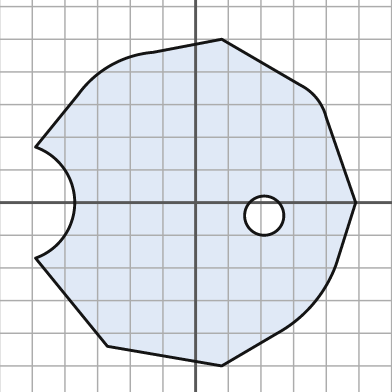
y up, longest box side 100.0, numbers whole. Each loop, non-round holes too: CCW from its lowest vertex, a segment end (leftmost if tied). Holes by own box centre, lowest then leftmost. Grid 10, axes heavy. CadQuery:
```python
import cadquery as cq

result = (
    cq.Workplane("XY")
    .moveTo(8.0, -50.0)
    .lineTo(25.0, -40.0)
    .threePointArc((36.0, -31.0), (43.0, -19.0))
    .lineTo(49.0, 0.0)
    .lineTo(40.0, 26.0)
    .threePointArc((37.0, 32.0), (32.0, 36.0))
    .lineTo(8.0, 50.0)
    .lineTo(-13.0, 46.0)
    .threePointArc((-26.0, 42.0), (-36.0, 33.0))
    .lineTo(-49.0, 17.0)
    .threePointArc((-37.0, 0.0), (-49.0, -17.0))
    .lineTo(-27.0, -44.0)
    .close()
    .moveTo(21.0, -4.0)
    .circle(6.0)
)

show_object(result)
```